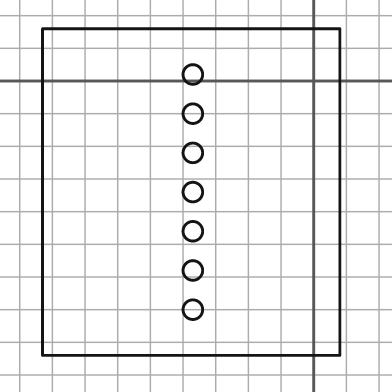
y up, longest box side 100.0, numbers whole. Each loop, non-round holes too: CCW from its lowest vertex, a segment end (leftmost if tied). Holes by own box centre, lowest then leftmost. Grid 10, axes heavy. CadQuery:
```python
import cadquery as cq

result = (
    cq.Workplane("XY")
    .moveTo(-83.0, -84.0)
    .lineTo(8.0, -84.0)
    .lineTo(8.0, 16.0)
    .lineTo(-83.0, 16.0)
    .close()
    .moveTo(-37.0, -70.0)
    .circle(3.0)
    .moveTo(-37.0, -58.0)
    .circle(3.0)
    .moveTo(-37.0, -46.0)
    .circle(3.0)
    .moveTo(-37.0, -34.0)
    .circle(3.0)
    .moveTo(-37.0, -22.0)
    .circle(3.0)
    .moveTo(-37.0, -10.0)
    .circle(3.0)
    .moveTo(-37.0, 2.0)
    .circle(3.0)
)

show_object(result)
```